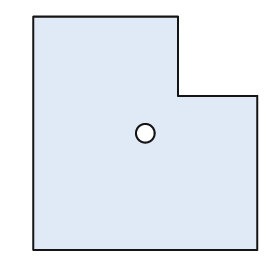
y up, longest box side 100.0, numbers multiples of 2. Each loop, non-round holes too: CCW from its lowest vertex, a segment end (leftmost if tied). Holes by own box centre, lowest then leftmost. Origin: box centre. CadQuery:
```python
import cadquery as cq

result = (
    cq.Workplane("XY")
    .moveTo(-48.0, -50.0)
    .lineTo(48.0, -50.0)
    .lineTo(48.0, 16.0)
    .lineTo(14.0, 16.0)
    .lineTo(14.0, 50.0)
    .lineTo(-48.0, 50.0)
    .close()
    .moveTo(0.0, 0.0)
    .circle(4.0)
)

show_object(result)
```